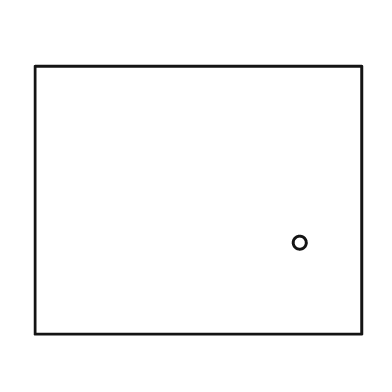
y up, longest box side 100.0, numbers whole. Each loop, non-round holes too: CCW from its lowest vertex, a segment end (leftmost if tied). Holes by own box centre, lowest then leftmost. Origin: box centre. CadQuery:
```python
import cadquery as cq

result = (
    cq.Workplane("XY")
    .moveTo(-50.0, -41.0)
    .lineTo(50.0, -41.0)
    .lineTo(50.0, 41.0)
    .lineTo(-50.0, 41.0)
    .close()
    .moveTo(31.0, -13.0)
    .circle(2.0)
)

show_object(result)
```